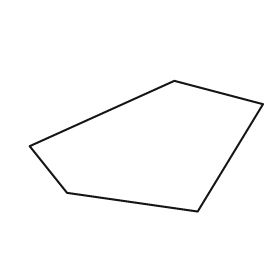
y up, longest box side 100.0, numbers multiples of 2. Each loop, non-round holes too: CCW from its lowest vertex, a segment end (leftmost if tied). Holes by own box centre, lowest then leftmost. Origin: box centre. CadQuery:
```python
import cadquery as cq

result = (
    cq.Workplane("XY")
    .moveTo(22.0, -28.0)
    .lineTo(50.0, 18.0)
    .lineTo(12.0, 28.0)
    .lineTo(-50.0, 0.0)
    .lineTo(-34.0, -20.0)
    .close()
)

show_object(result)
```